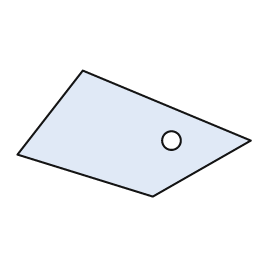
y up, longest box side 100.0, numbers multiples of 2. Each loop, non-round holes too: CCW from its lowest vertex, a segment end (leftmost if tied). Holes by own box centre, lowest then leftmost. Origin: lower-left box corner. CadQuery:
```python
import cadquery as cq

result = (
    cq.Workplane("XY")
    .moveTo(58.0, 0.0)
    .lineTo(100.0, 24.0)
    .lineTo(28.0, 54.0)
    .lineTo(0.0, 18.0)
    .close()
    .moveTo(66.0, 24.0)
    .circle(4.0)
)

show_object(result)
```